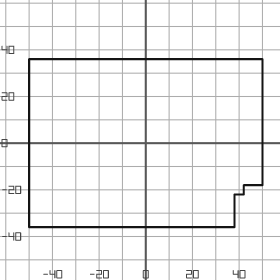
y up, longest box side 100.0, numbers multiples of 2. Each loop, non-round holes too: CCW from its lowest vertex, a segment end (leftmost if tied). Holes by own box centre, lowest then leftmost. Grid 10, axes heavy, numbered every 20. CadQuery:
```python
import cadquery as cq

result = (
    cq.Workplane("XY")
    .moveTo(-50.0, -36.0)
    .lineTo(38.0, -36.0)
    .lineTo(38.0, -22.0)
    .lineTo(42.0, -22.0)
    .lineTo(42.0, -18.0)
    .lineTo(50.0, -18.0)
    .lineTo(50.0, 36.0)
    .lineTo(-50.0, 36.0)
    .close()
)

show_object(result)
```